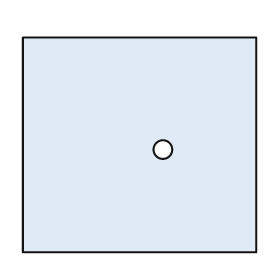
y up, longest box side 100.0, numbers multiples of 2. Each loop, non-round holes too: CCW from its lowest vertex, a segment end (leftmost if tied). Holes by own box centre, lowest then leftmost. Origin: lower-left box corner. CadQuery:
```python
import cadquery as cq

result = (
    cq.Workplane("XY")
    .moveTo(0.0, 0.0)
    .lineTo(100.0, 0.0)
    .lineTo(100.0, 92.0)
    .lineTo(0.0, 92.0)
    .close()
    .moveTo(60.0, 44.0)
    .circle(4.0)
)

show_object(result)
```